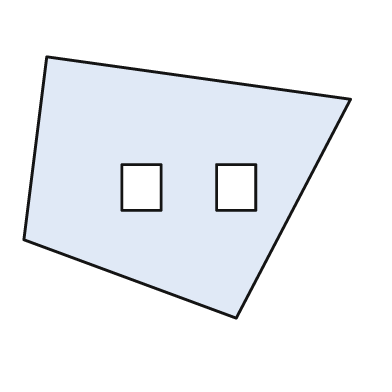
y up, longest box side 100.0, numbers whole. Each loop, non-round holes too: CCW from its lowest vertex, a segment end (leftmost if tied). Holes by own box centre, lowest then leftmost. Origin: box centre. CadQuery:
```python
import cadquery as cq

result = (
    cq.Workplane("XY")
    .moveTo(15.0, -40.0)
    .lineTo(50.0, 27.0)
    .lineTo(-43.0, 40.0)
    .lineTo(-50.0, -16.0)
    .close()
    .moveTo(-20.0, -7.0)
    .lineTo(-8.0, -7.0)
    .lineTo(-8.0, 7.0)
    .lineTo(-20.0, 7.0)
    .close()
    .moveTo(9.0, -7.0)
    .lineTo(21.0, -7.0)
    .lineTo(21.0, 7.0)
    .lineTo(9.0, 7.0)
    .close()
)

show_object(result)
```